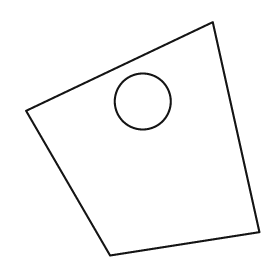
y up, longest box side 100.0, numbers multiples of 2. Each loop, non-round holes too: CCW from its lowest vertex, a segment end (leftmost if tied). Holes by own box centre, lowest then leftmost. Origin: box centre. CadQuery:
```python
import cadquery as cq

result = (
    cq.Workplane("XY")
    .moveTo(-14.0, -50.0)
    .lineTo(50.0, -40.0)
    .lineTo(30.0, 50.0)
    .lineTo(-50.0, 12.0)
    .close()
    .moveTo(0.0, 16.0)
    .circle(12.0)
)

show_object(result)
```